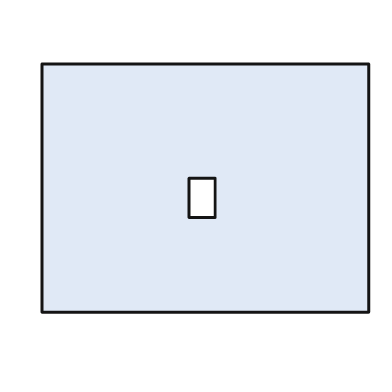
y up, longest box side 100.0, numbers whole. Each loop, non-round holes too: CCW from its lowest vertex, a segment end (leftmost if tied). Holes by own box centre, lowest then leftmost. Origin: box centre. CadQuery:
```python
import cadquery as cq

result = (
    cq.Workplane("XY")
    .moveTo(-50.0, -38.0)
    .lineTo(50.0, -38.0)
    .lineTo(50.0, 38.0)
    .lineTo(-50.0, 38.0)
    .close()
    .moveTo(-5.0, -9.0)
    .lineTo(3.0, -9.0)
    .lineTo(3.0, 3.0)
    .lineTo(-5.0, 3.0)
    .close()
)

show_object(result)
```